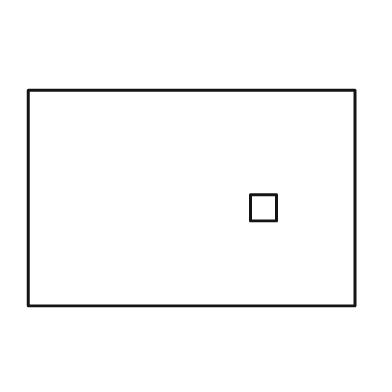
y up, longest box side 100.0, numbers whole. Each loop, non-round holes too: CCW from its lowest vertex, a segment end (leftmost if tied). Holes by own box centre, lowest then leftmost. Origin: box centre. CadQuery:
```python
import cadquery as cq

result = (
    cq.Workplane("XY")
    .moveTo(-50.0, -33.0)
    .lineTo(50.0, -33.0)
    .lineTo(50.0, 33.0)
    .lineTo(-50.0, 33.0)
    .close()
    .moveTo(18.0, -7.0)
    .lineTo(26.0, -7.0)
    .lineTo(26.0, 1.0)
    .lineTo(18.0, 1.0)
    .close()
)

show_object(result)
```